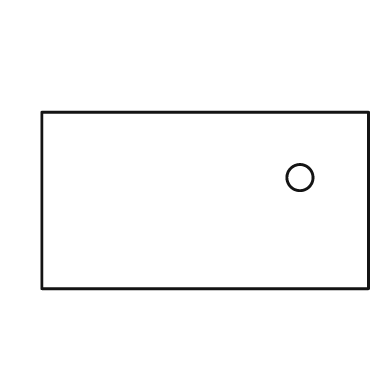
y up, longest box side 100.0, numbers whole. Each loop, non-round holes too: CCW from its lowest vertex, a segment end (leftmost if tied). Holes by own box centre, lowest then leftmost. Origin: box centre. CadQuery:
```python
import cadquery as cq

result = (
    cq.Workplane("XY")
    .moveTo(-50.0, -27.0)
    .lineTo(50.0, -27.0)
    .lineTo(50.0, 27.0)
    .lineTo(-50.0, 27.0)
    .close()
    .moveTo(29.0, 7.0)
    .circle(4.0)
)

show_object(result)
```